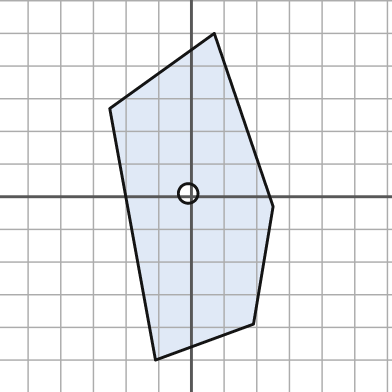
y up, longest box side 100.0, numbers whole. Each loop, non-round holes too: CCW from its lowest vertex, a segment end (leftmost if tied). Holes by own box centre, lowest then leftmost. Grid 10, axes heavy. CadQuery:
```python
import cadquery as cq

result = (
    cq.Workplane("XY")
    .moveTo(-11.0, -50.0)
    .lineTo(19.0, -39.0)
    .lineTo(25.0, -3.0)
    .lineTo(7.0, 50.0)
    .lineTo(-25.0, 27.0)
    .close()
    .moveTo(-1.0, 1.0)
    .circle(3.0)
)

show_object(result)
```